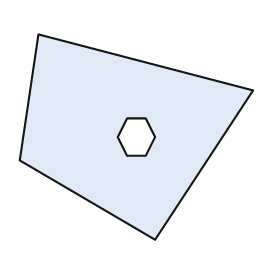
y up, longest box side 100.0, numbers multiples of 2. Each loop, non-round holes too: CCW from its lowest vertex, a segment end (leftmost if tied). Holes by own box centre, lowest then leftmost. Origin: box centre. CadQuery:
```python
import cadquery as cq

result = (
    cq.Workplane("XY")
    .moveTo(8.0, -44.0)
    .lineTo(50.0, 20.0)
    .lineTo(-42.0, 44.0)
    .lineTo(-50.0, -10.0)
    .close()
    .moveTo(-4.0, -8.0)
    .lineTo(4.0, -8.0)
    .lineTo(8.0, 0.0)
    .lineTo(4.0, 8.0)
    .lineTo(-4.0, 8.0)
    .lineTo(-8.0, 0.0)
    .close()
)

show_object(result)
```